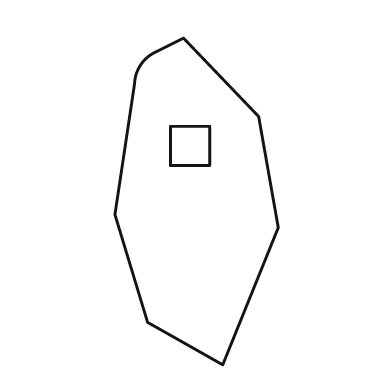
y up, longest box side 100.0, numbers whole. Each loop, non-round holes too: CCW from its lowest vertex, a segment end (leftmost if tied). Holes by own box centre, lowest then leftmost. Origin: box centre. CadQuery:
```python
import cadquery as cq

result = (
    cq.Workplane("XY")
    .moveTo(8.0, -50.0)
    .lineTo(25.0, -8.0)
    .lineTo(19.0, 26.0)
    .lineTo(-4.0, 50.0)
    .lineTo(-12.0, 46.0)
    .threePointArc((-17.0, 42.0), (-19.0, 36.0))
    .lineTo(-25.0, -4.0)
    .lineTo(-15.0, -37.0)
    .close()
    .moveTo(-8.0, 11.0)
    .lineTo(4.0, 11.0)
    .lineTo(4.0, 23.0)
    .lineTo(-8.0, 23.0)
    .close()
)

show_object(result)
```